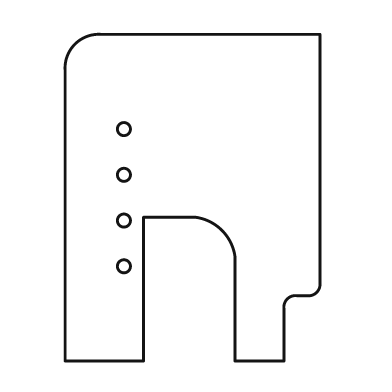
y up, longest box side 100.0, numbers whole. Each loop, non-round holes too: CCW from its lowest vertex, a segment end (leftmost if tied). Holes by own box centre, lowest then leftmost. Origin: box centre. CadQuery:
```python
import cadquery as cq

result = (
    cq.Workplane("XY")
    .moveTo(-39.0, -50.0)
    .lineTo(-15.0, -50.0)
    .lineTo(-15.0, -6.0)
    .lineTo(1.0, -6.0)
    .threePointArc((9.0, -10.0), (13.0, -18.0))
    .lineTo(13.0, -50.0)
    .lineTo(28.0, -50.0)
    .lineTo(28.0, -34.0)
    .threePointArc((29.0, -31.0), (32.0, -30.0))
    .lineTo(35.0, -30.0)
    .threePointArc((38.0, -29.0), (39.0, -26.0))
    .lineTo(39.0, 50.0)
    .lineTo(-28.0, 50.0)
    .threePointArc((-36.0, 47.0), (-39.0, 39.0))
    .close()
    .moveTo(-21.0, -21.0)
    .circle(2.0)
    .moveTo(-21.0, -7.0)
    .circle(2.0)
    .moveTo(-21.0, 7.0)
    .circle(2.0)
    .moveTo(-21.0, 21.0)
    .circle(2.0)
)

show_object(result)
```